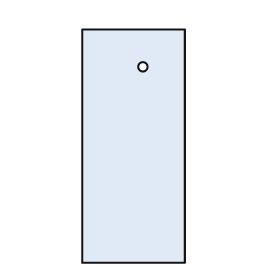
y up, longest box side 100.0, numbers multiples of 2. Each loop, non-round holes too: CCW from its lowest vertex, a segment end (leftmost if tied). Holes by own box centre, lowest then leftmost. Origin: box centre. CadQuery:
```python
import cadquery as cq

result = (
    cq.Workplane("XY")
    .moveTo(-22.0, -50.0)
    .lineTo(22.0, -50.0)
    .lineTo(22.0, 50.0)
    .lineTo(-22.0, 50.0)
    .close()
    .moveTo(4.0, 34.0)
    .circle(2.0)
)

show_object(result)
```